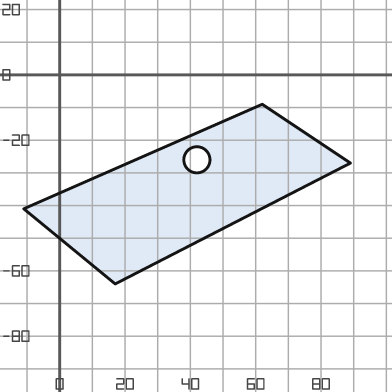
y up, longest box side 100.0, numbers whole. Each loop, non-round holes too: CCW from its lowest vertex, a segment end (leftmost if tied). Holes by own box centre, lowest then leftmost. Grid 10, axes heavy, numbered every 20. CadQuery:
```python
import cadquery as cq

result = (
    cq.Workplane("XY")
    .moveTo(17.0, -64.0)
    .lineTo(89.0, -27.0)
    .lineTo(62.0, -9.0)
    .lineTo(-11.0, -41.0)
    .close()
    .moveTo(42.0, -26.0)
    .circle(4.0)
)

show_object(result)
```